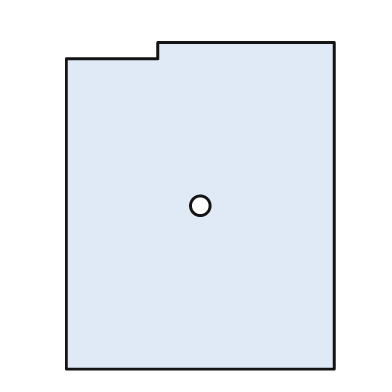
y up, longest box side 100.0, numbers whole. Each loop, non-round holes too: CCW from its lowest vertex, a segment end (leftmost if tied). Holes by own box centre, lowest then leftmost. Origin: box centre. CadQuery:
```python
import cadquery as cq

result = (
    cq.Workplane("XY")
    .moveTo(-41.0, -50.0)
    .lineTo(41.0, -50.0)
    .lineTo(41.0, 50.0)
    .lineTo(-13.0, 50.0)
    .lineTo(-13.0, 45.0)
    .lineTo(-41.0, 45.0)
    .close()
    .moveTo(0.0, 0.0)
    .circle(3.0)
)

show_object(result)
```